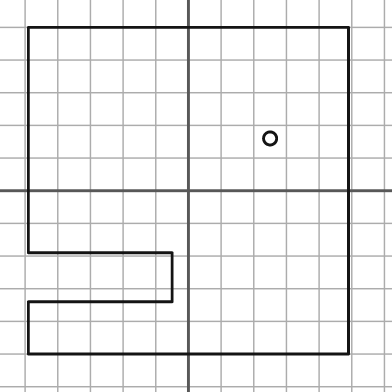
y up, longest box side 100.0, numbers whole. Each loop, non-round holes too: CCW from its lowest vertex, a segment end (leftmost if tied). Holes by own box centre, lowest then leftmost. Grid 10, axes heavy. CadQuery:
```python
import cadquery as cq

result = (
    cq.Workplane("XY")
    .moveTo(-49.0, -50.0)
    .lineTo(49.0, -50.0)
    .lineTo(49.0, 50.0)
    .lineTo(-49.0, 50.0)
    .lineTo(-49.0, -19.0)
    .lineTo(-5.0, -19.0)
    .lineTo(-5.0, -34.0)
    .lineTo(-49.0, -34.0)
    .close()
    .moveTo(25.0, 16.0)
    .circle(2.0)
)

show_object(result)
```